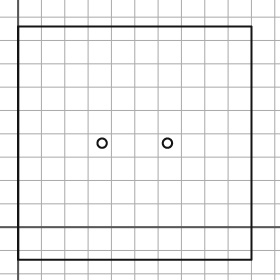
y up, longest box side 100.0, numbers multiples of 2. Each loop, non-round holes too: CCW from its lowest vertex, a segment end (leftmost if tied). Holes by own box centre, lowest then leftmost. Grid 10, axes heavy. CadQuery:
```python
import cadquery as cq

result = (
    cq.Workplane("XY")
    .moveTo(0.0, -14.0)
    .lineTo(100.0, -14.0)
    .lineTo(100.0, 86.0)
    .lineTo(0.0, 86.0)
    .close()
    .moveTo(36.0, 36.0)
    .circle(2.0)
    .moveTo(64.0, 36.0)
    .circle(2.0)
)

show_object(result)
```